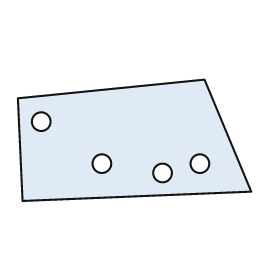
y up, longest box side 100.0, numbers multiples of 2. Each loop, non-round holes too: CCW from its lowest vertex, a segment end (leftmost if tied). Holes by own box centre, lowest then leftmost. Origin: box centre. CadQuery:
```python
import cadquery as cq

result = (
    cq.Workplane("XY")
    .moveTo(-48.0, -26.0)
    .lineTo(50.0, -22.0)
    .lineTo(30.0, 26.0)
    .lineTo(-50.0, 18.0)
    .close()
    .moveTo(12.0, -14.0)
    .circle(4.0)
    .moveTo(-14.0, -10.0)
    .circle(4.0)
    .moveTo(28.0, -10.0)
    .circle(4.0)
    .moveTo(-40.0, 8.0)
    .circle(4.0)
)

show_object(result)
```